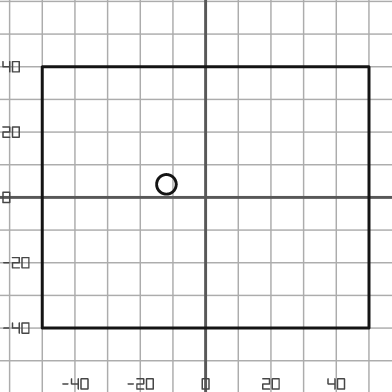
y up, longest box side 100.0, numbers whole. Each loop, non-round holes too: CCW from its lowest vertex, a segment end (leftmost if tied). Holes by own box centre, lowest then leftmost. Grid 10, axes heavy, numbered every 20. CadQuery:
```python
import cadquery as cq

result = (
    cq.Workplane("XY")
    .moveTo(-50.0, -40.0)
    .lineTo(50.0, -40.0)
    .lineTo(50.0, 40.0)
    .lineTo(-50.0, 40.0)
    .close()
    .moveTo(-12.0, 4.0)
    .circle(3.0)
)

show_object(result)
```